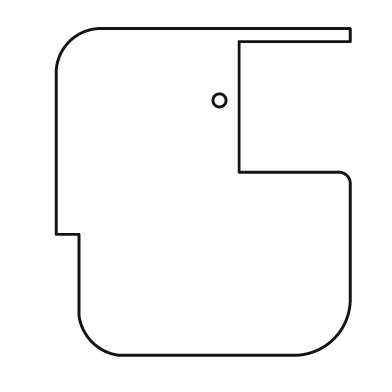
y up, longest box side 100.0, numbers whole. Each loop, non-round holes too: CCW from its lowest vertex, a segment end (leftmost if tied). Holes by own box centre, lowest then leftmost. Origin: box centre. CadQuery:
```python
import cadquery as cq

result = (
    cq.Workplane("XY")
    .moveTo(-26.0, -50.0)
    .lineTo(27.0, -50.0)
    .threePointArc((40.0, -45.0), (45.0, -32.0))
    .lineTo(45.0, 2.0)
    .threePointArc((44.0, 5.0), (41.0, 6.0))
    .lineTo(11.0, 6.0)
    .lineTo(11.0, 46.0)
    .lineTo(45.0, 46.0)
    .lineTo(45.0, 50.0)
    .lineTo(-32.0, 50.0)
    .threePointArc((-41.0, 46.0), (-45.0, 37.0))
    .lineTo(-45.0, -13.0)
    .lineTo(-38.0, -13.0)
    .lineTo(-38.0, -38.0)
    .threePointArc((-34.0, -46.0), (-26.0, -50.0))
    .close()
    .moveTo(5.0, 28.0)
    .circle(2.0)
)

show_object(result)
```